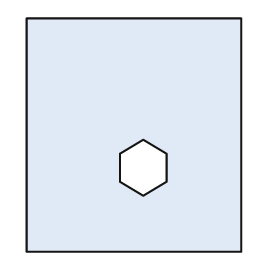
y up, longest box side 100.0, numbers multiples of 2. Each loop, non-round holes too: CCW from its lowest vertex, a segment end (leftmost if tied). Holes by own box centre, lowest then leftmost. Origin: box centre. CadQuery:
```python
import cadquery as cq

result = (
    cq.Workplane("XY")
    .moveTo(-46.0, -50.0)
    .lineTo(46.0, -50.0)
    .lineTo(46.0, 50.0)
    .lineTo(-46.0, 50.0)
    .close()
    .moveTo(4.0, -26.0)
    .lineTo(14.0, -20.0)
    .lineTo(14.0, -8.0)
    .lineTo(4.0, -2.0)
    .lineTo(-6.0, -8.0)
    .lineTo(-6.0, -20.0)
    .close()
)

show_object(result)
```